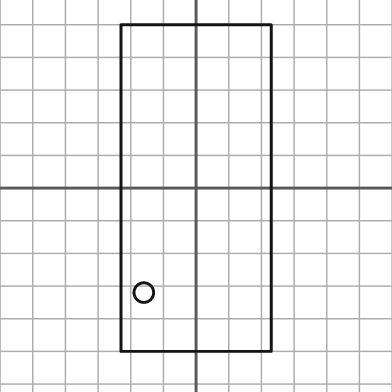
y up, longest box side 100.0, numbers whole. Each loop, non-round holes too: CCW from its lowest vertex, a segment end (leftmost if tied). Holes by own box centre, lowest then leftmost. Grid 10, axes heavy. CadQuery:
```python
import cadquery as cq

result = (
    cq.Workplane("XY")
    .moveTo(-23.0, -50.0)
    .lineTo(23.0, -50.0)
    .lineTo(23.0, 50.0)
    .lineTo(-23.0, 50.0)
    .close()
    .moveTo(-16.0, -32.0)
    .circle(3.0)
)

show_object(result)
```